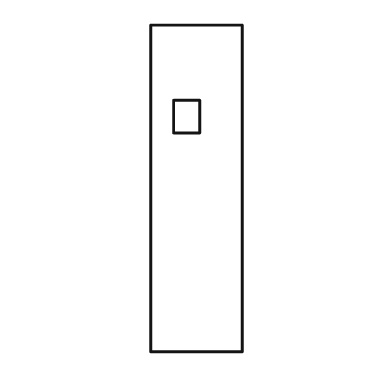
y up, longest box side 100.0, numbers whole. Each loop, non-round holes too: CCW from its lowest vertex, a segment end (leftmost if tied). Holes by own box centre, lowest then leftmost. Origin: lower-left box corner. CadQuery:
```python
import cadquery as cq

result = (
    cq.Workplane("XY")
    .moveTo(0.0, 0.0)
    .lineTo(28.0, 0.0)
    .lineTo(28.0, 100.0)
    .lineTo(0.0, 100.0)
    .close()
    .moveTo(7.0, 67.0)
    .lineTo(15.0, 67.0)
    .lineTo(15.0, 77.0)
    .lineTo(7.0, 77.0)
    .close()
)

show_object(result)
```